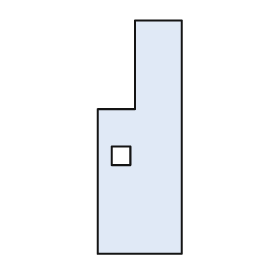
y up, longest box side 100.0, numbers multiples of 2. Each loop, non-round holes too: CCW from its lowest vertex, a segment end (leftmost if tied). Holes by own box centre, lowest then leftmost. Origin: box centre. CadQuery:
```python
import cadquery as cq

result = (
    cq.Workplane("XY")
    .moveTo(-18.0, -50.0)
    .lineTo(18.0, -50.0)
    .lineTo(18.0, 50.0)
    .lineTo(-2.0, 50.0)
    .lineTo(-2.0, 12.0)
    .lineTo(-18.0, 12.0)
    .close()
    .moveTo(-12.0, -12.0)
    .lineTo(-4.0, -12.0)
    .lineTo(-4.0, -4.0)
    .lineTo(-12.0, -4.0)
    .close()
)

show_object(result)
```